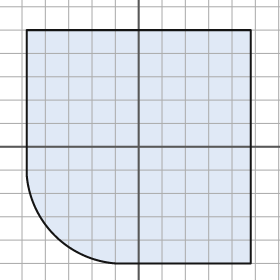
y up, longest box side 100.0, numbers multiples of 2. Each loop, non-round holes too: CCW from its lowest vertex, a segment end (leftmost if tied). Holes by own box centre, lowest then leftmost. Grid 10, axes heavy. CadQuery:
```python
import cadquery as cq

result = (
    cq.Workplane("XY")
    .moveTo(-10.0, -50.0)
    .lineTo(48.0, -50.0)
    .lineTo(48.0, 50.0)
    .lineTo(-48.0, 50.0)
    .lineTo(-48.0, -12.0)
    .threePointArc((-36.0, -38.0), (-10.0, -50.0))
    .close()
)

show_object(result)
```